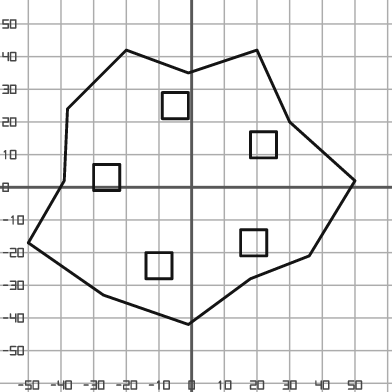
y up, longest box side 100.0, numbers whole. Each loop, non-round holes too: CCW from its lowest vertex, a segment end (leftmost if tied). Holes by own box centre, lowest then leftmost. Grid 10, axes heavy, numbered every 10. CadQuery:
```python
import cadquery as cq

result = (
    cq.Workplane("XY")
    .moveTo(-1.0, -42.0)
    .lineTo(18.0, -28.0)
    .lineTo(36.0, -21.0)
    .lineTo(50.0, 2.0)
    .lineTo(30.0, 20.0)
    .lineTo(20.0, 42.0)
    .lineTo(-1.0, 35.0)
    .lineTo(-20.0, 42.0)
    .lineTo(-38.0, 24.0)
    .lineTo(-39.0, 2.0)
    .lineTo(-50.0, -17.0)
    .lineTo(-27.0, -33.0)
    .close()
    .moveTo(-14.0, -28.0)
    .lineTo(-6.0, -28.0)
    .lineTo(-6.0, -20.0)
    .lineTo(-14.0, -20.0)
    .close()
    .moveTo(15.0, -21.0)
    .lineTo(23.0, -21.0)
    .lineTo(23.0, -13.0)
    .lineTo(15.0, -13.0)
    .close()
    .moveTo(-30.0, -1.0)
    .lineTo(-22.0, -1.0)
    .lineTo(-22.0, 7.0)
    .lineTo(-30.0, 7.0)
    .close()
    .moveTo(18.0, 9.0)
    .lineTo(26.0, 9.0)
    .lineTo(26.0, 17.0)
    .lineTo(18.0, 17.0)
    .close()
    .moveTo(-9.0, 21.0)
    .lineTo(-1.0, 21.0)
    .lineTo(-1.0, 29.0)
    .lineTo(-9.0, 29.0)
    .close()
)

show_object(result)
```